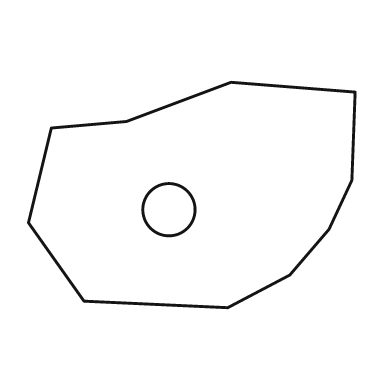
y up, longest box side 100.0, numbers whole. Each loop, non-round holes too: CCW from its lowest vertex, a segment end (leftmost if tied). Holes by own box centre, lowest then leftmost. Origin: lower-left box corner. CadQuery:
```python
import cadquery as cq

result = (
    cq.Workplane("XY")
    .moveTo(61.0, 0.0)
    .lineTo(80.0, 10.0)
    .lineTo(92.0, 24.0)
    .lineTo(99.0, 39.0)
    .lineTo(100.0, 66.0)
    .lineTo(62.0, 69.0)
    .lineTo(30.0, 57.0)
    .lineTo(7.0, 55.0)
    .lineTo(0.0, 26.0)
    .lineTo(17.0, 2.0)
    .close()
    .moveTo(43.0, 30.0)
    .circle(8.0)
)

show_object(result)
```